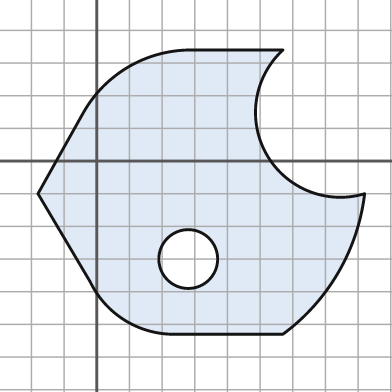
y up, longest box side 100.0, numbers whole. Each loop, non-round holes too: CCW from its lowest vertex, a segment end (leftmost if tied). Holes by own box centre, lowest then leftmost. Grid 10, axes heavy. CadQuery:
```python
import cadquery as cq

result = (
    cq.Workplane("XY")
    .moveTo(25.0, -53.0)
    .lineTo(57.0, -53.0)
    .threePointArc((74.0, -34.0), (82.0, -10.0))
    .threePointArc((52.0, 2.0), (57.0, 34.0))
    .lineTo(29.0, 34.0)
    .threePointArc((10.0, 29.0), (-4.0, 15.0))
    .lineTo(-18.0, -10.0)
    .lineTo(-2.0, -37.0)
    .threePointArc((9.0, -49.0), (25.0, -53.0))
    .close()
    .moveTo(28.0, -30.0)
    .circle(9.0)
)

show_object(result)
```